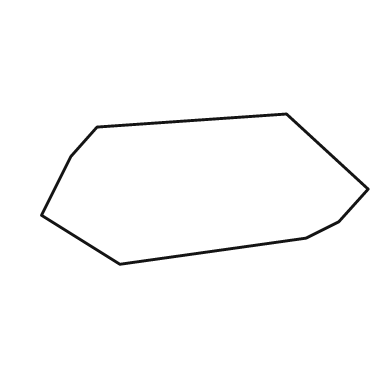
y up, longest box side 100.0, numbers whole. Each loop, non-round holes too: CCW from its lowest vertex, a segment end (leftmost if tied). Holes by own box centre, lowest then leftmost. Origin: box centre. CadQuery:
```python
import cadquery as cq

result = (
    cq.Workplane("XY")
    .moveTo(-26.0, -23.0)
    .lineTo(31.0, -15.0)
    .lineTo(41.0, -10.0)
    .lineTo(50.0, 0.0)
    .lineTo(25.0, 23.0)
    .lineTo(-33.0, 19.0)
    .lineTo(-41.0, 10.0)
    .lineTo(-50.0, -8.0)
    .close()
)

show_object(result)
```